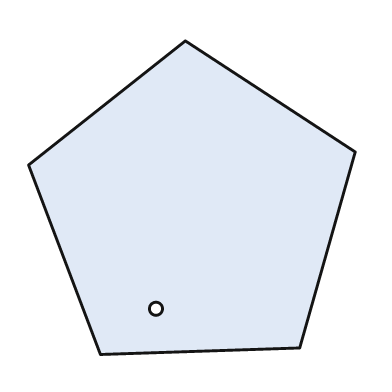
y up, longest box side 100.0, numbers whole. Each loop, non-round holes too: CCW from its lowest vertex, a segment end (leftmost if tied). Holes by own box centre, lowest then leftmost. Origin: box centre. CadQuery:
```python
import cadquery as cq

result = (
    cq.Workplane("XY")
    .moveTo(-28.0, -48.0)
    .lineTo(33.0, -46.0)
    .lineTo(50.0, 14.0)
    .lineTo(-2.0, 48.0)
    .lineTo(-50.0, 10.0)
    .close()
    .moveTo(-11.0, -34.0)
    .circle(2.0)
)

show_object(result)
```